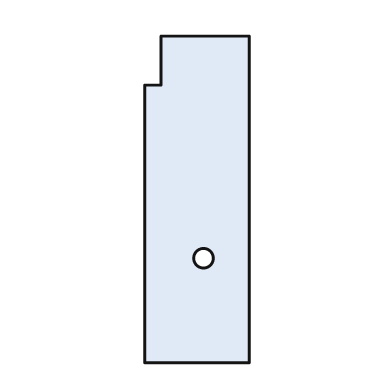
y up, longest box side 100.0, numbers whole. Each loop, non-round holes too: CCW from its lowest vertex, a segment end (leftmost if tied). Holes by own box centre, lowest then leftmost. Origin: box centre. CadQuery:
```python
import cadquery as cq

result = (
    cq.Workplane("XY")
    .moveTo(-16.0, -50.0)
    .lineTo(16.0, -50.0)
    .lineTo(16.0, 50.0)
    .lineTo(-11.0, 50.0)
    .lineTo(-11.0, 35.0)
    .lineTo(-16.0, 35.0)
    .close()
    .moveTo(2.0, -18.0)
    .circle(3.0)
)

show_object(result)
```